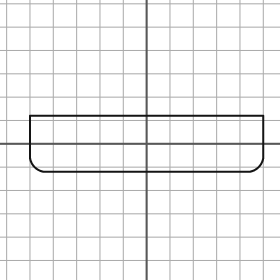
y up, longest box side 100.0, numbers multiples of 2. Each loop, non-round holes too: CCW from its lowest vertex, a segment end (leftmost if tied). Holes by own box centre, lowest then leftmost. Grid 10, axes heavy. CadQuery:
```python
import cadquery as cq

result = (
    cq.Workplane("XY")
    .moveTo(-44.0, -12.0)
    .lineTo(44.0, -12.0)
    .threePointArc((48.0, -10.0), (50.0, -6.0))
    .lineTo(50.0, 12.0)
    .lineTo(-50.0, 12.0)
    .lineTo(-50.0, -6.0)
    .threePointArc((-48.0, -10.0), (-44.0, -12.0))
    .close()
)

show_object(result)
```